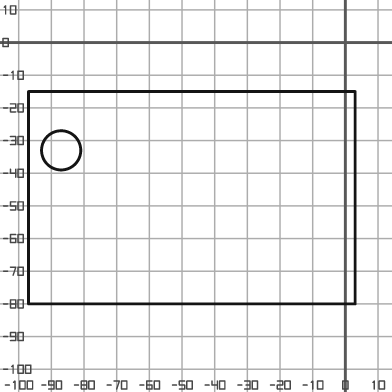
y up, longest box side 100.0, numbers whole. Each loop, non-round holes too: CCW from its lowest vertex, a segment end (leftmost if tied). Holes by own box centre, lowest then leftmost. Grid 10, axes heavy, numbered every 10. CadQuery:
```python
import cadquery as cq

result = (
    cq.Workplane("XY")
    .moveTo(-97.0, -80.0)
    .lineTo(3.0, -80.0)
    .lineTo(3.0, -15.0)
    .lineTo(-97.0, -15.0)
    .close()
    .moveTo(-87.0, -33.0)
    .circle(6.0)
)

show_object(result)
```